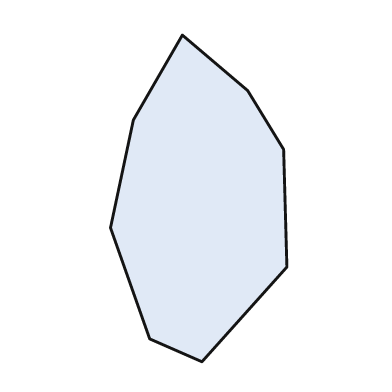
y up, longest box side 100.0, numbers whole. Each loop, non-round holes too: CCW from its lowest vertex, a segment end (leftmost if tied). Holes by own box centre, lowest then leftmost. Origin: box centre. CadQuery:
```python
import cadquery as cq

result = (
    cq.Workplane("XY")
    .moveTo(1.0, -50.0)
    .lineTo(27.0, -21.0)
    .lineTo(26.0, 15.0)
    .lineTo(15.0, 33.0)
    .lineTo(-5.0, 50.0)
    .lineTo(-20.0, 24.0)
    .lineTo(-27.0, -9.0)
    .lineTo(-15.0, -43.0)
    .close()
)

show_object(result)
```